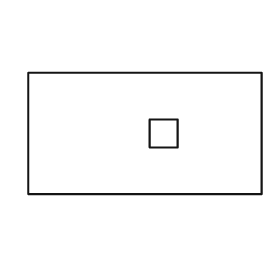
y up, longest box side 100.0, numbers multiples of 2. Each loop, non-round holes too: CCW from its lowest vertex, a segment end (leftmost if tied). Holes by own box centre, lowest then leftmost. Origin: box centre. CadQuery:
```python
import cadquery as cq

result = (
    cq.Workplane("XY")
    .moveTo(-50.0, -26.0)
    .lineTo(50.0, -26.0)
    .lineTo(50.0, 26.0)
    .lineTo(-50.0, 26.0)
    .close()
    .moveTo(2.0, -6.0)
    .lineTo(14.0, -6.0)
    .lineTo(14.0, 6.0)
    .lineTo(2.0, 6.0)
    .close()
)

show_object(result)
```